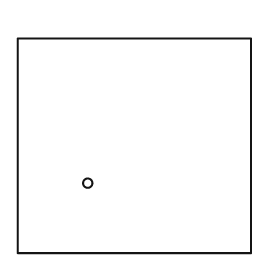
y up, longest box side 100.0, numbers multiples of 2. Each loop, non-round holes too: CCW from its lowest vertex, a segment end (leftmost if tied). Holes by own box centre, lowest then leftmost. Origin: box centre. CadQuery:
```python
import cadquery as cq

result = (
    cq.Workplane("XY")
    .moveTo(-50.0, -46.0)
    .lineTo(50.0, -46.0)
    .lineTo(50.0, 46.0)
    .lineTo(-50.0, 46.0)
    .close()
    .moveTo(-20.0, -16.0)
    .circle(2.0)
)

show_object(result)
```